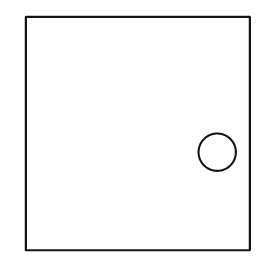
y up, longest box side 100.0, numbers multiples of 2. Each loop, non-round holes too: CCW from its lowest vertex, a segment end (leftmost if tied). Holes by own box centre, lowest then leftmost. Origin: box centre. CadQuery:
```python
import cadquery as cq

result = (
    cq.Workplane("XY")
    .moveTo(-48.0, -50.0)
    .lineTo(48.0, -50.0)
    .lineTo(48.0, 50.0)
    .lineTo(-48.0, 50.0)
    .close()
    .moveTo(34.0, -8.0)
    .circle(8.0)
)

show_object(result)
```